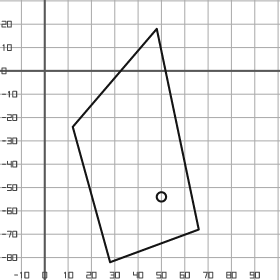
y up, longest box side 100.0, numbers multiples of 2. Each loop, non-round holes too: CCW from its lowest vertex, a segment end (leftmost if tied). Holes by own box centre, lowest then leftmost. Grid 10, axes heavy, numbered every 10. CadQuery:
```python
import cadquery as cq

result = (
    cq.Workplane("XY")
    .moveTo(28.0, -82.0)
    .lineTo(66.0, -68.0)
    .lineTo(48.0, 18.0)
    .lineTo(12.0, -24.0)
    .close()
    .moveTo(50.0, -54.0)
    .circle(2.0)
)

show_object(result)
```